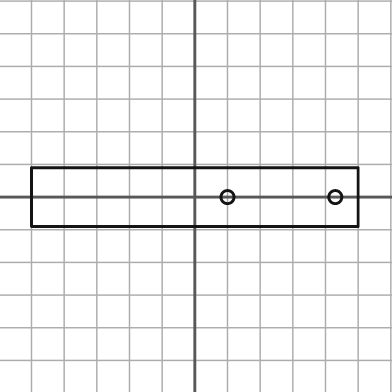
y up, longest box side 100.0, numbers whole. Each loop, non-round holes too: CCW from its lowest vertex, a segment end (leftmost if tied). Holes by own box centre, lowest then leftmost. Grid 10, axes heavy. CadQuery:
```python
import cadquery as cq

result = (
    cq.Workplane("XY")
    .moveTo(-50.0, -9.0)
    .lineTo(50.0, -9.0)
    .lineTo(50.0, 9.0)
    .lineTo(-50.0, 9.0)
    .close()
    .moveTo(10.0, 0.0)
    .circle(2.0)
    .moveTo(43.0, 0.0)
    .circle(2.0)
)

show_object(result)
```